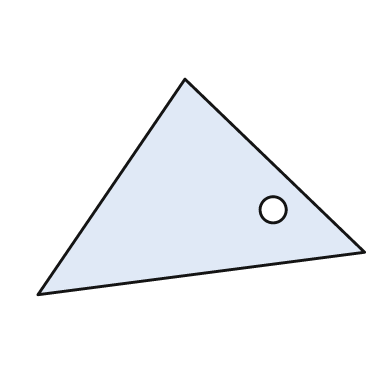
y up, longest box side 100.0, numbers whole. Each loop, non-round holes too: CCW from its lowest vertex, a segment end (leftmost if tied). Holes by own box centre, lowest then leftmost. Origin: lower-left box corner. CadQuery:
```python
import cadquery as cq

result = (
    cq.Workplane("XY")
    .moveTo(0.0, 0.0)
    .lineTo(100.0, 13.0)
    .lineTo(45.0, 66.0)
    .close()
    .moveTo(72.0, 26.0)
    .circle(4.0)
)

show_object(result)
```